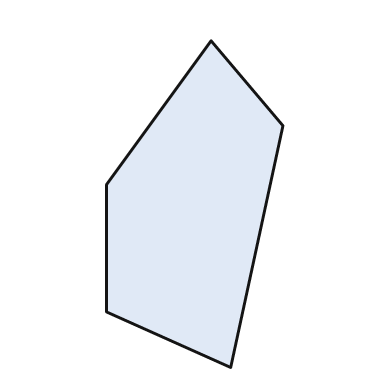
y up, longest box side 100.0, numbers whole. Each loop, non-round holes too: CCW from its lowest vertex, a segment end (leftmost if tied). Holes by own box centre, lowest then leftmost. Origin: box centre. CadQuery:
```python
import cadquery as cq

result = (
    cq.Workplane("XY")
    .moveTo(11.0, -50.0)
    .lineTo(27.0, 24.0)
    .lineTo(5.0, 50.0)
    .lineTo(-27.0, 6.0)
    .lineTo(-27.0, -33.0)
    .close()
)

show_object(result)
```